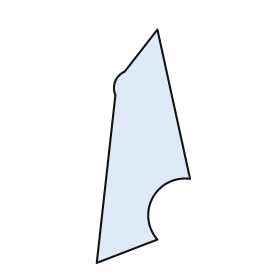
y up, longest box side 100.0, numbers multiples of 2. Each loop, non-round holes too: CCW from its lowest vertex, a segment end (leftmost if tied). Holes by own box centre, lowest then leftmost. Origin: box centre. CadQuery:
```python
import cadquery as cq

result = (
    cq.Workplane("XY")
    .moveTo(-20.0, -50.0)
    .lineTo(6.0, -40.0)
    .threePointArc((4.0, -22.0), (20.0, -14.0))
    .lineTo(6.0, 50.0)
    .lineTo(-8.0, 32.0)
    .threePointArc((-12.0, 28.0), (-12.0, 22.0))
    .close()
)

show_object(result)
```